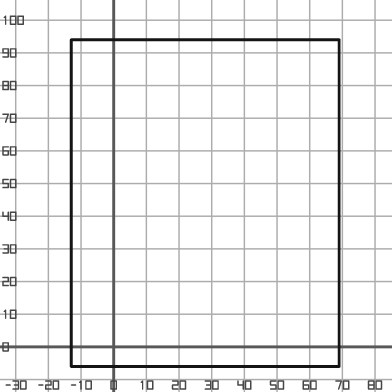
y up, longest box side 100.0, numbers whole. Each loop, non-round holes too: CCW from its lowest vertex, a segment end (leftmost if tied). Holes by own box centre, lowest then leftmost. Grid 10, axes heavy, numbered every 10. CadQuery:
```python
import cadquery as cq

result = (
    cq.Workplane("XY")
    .moveTo(-13.0, -6.0)
    .lineTo(69.0, -6.0)
    .lineTo(69.0, 94.0)
    .lineTo(-13.0, 94.0)
    .close()
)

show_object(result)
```